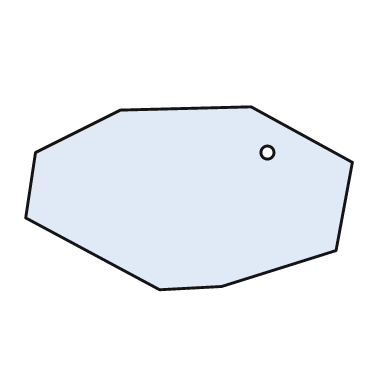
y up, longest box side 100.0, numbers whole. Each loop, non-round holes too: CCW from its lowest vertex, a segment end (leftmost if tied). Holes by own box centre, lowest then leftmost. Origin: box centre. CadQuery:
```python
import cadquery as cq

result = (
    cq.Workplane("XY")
    .moveTo(-9.0, -28.0)
    .lineTo(10.0, -27.0)
    .lineTo(45.0, -16.0)
    .lineTo(50.0, 11.0)
    .lineTo(19.0, 28.0)
    .lineTo(-21.0, 27.0)
    .lineTo(-47.0, 14.0)
    .lineTo(-50.0, -6.0)
    .close()
    .moveTo(24.0, 14.0)
    .circle(2.0)
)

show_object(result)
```